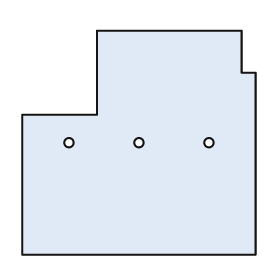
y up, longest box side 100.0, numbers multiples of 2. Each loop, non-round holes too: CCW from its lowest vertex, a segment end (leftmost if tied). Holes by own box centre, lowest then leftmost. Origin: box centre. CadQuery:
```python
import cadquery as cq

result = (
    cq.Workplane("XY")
    .moveTo(-50.0, -48.0)
    .lineTo(50.0, -48.0)
    .lineTo(50.0, 30.0)
    .lineTo(44.0, 30.0)
    .lineTo(44.0, 48.0)
    .lineTo(-18.0, 48.0)
    .lineTo(-18.0, 12.0)
    .lineTo(-50.0, 12.0)
    .close()
    .moveTo(-30.0, 0.0)
    .circle(2.0)
    .moveTo(0.0, 0.0)
    .circle(2.0)
    .moveTo(30.0, 0.0)
    .circle(2.0)
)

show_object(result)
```